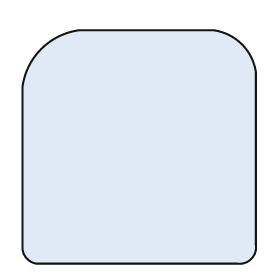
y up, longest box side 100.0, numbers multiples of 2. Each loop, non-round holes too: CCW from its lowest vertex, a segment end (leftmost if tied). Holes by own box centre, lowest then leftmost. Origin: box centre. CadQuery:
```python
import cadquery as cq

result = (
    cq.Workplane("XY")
    .moveTo(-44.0, -50.0)
    .lineTo(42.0, -50.0)
    .threePointArc((48.0, -48.0), (50.0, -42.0))
    .lineTo(50.0, 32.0)
    .threePointArc((44.0, 44.0), (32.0, 50.0))
    .lineTo(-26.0, 50.0)
    .threePointArc((-42.0, 42.0), (-50.0, 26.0))
    .lineTo(-50.0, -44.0)
    .threePointArc((-48.0, -48.0), (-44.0, -50.0))
    .close()
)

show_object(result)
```